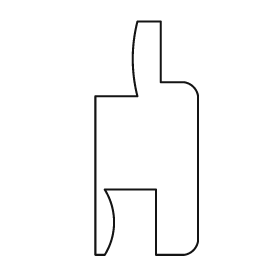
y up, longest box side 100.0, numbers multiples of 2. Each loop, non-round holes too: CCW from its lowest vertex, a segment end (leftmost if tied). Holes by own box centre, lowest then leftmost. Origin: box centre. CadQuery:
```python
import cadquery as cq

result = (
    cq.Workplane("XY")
    .moveTo(-22.0, -50.0)
    .lineTo(-18.0, -50.0)
    .threePointArc((-14.0, -36.0), (-18.0, -22.0))
    .lineTo(4.0, -22.0)
    .lineTo(4.0, -50.0)
    .lineTo(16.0, -50.0)
    .threePointArc((20.0, -48.0), (22.0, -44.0))
    .lineTo(22.0, 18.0)
    .threePointArc((20.0, 22.0), (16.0, 24.0))
    .lineTo(6.0, 24.0)
    .lineTo(6.0, 50.0)
    .lineTo(-4.0, 50.0)
    .threePointArc((-6.0, 34.0), (-4.0, 18.0))
    .lineTo(-22.0, 18.0)
    .close()
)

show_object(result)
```